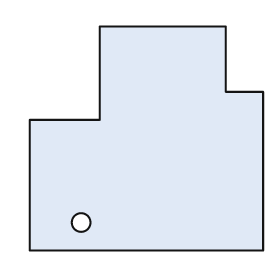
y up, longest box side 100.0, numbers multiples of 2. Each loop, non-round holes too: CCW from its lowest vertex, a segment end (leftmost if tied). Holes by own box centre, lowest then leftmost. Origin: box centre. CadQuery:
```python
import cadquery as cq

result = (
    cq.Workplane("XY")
    .moveTo(-50.0, -48.0)
    .lineTo(50.0, -48.0)
    .lineTo(50.0, 20.0)
    .lineTo(34.0, 20.0)
    .lineTo(34.0, 48.0)
    .lineTo(-20.0, 48.0)
    .lineTo(-20.0, 8.0)
    .lineTo(-50.0, 8.0)
    .close()
    .moveTo(-28.0, -36.0)
    .circle(4.0)
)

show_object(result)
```